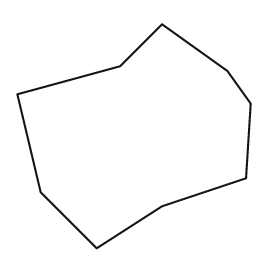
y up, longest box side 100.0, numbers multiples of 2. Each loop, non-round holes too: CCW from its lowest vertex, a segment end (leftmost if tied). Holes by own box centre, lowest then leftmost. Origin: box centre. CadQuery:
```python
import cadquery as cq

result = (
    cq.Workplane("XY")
    .moveTo(-16.0, -48.0)
    .lineTo(12.0, -30.0)
    .lineTo(48.0, -18.0)
    .lineTo(50.0, 14.0)
    .lineTo(40.0, 28.0)
    .lineTo(12.0, 48.0)
    .lineTo(-6.0, 30.0)
    .lineTo(-50.0, 18.0)
    .lineTo(-40.0, -24.0)
    .close()
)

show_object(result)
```